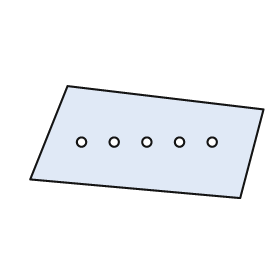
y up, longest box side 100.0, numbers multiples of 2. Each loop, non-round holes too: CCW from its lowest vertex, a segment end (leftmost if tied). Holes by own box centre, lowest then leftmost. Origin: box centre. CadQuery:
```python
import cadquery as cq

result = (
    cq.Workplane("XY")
    .moveTo(40.0, -24.0)
    .lineTo(50.0, 14.0)
    .lineTo(-34.0, 24.0)
    .lineTo(-50.0, -16.0)
    .close()
    .moveTo(-28.0, 0.0)
    .circle(2.0)
    .moveTo(-14.0, 0.0)
    .circle(2.0)
    .moveTo(0.0, 0.0)
    .circle(2.0)
    .moveTo(14.0, 0.0)
    .circle(2.0)
    .moveTo(28.0, 0.0)
    .circle(2.0)
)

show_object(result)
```